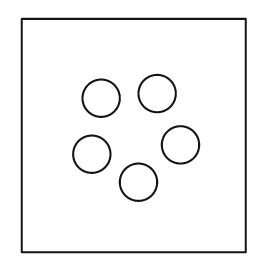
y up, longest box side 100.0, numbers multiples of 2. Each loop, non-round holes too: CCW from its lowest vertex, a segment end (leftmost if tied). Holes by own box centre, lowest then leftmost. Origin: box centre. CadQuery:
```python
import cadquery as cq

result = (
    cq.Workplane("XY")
    .moveTo(-48.0, -50.0)
    .lineTo(48.0, -50.0)
    .lineTo(48.0, 50.0)
    .lineTo(-48.0, 50.0)
    .close()
    .moveTo(2.0, -20.0)
    .circle(8.0)
    .moveTo(-18.0, -8.0)
    .circle(8.0)
    .moveTo(20.0, -4.0)
    .circle(8.0)
    .moveTo(-14.0, 16.0)
    .circle(8.0)
    .moveTo(10.0, 18.0)
    .circle(8.0)
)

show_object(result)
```